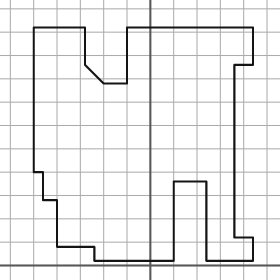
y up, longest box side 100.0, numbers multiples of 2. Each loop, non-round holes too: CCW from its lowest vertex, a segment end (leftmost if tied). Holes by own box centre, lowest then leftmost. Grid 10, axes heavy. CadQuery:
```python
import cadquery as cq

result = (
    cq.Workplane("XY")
    .moveTo(-24.0, 2.0)
    .lineTo(10.0, 2.0)
    .lineTo(10.0, 36.0)
    .lineTo(24.0, 36.0)
    .lineTo(24.0, 2.0)
    .lineTo(44.0, 2.0)
    .lineTo(44.0, 12.0)
    .lineTo(36.0, 12.0)
    .lineTo(36.0, 86.0)
    .lineTo(44.0, 86.0)
    .lineTo(44.0, 102.0)
    .lineTo(-10.0, 102.0)
    .lineTo(-10.0, 78.0)
    .lineTo(-20.0, 78.0)
    .lineTo(-28.0, 86.0)
    .lineTo(-28.0, 102.0)
    .lineTo(-50.0, 102.0)
    .lineTo(-50.0, 40.0)
    .lineTo(-46.0, 40.0)
    .lineTo(-46.0, 28.0)
    .lineTo(-40.0, 28.0)
    .lineTo(-40.0, 8.0)
    .lineTo(-24.0, 8.0)
    .close()
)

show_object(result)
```